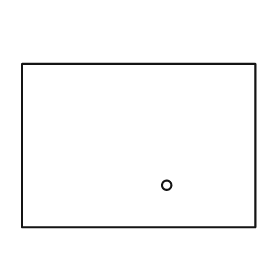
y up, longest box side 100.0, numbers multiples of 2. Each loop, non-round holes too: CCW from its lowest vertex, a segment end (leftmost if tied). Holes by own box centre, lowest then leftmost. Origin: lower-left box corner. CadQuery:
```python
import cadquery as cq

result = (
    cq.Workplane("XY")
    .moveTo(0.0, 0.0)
    .lineTo(100.0, 0.0)
    .lineTo(100.0, 70.0)
    .lineTo(0.0, 70.0)
    .close()
    .moveTo(62.0, 18.0)
    .circle(2.0)
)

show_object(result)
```